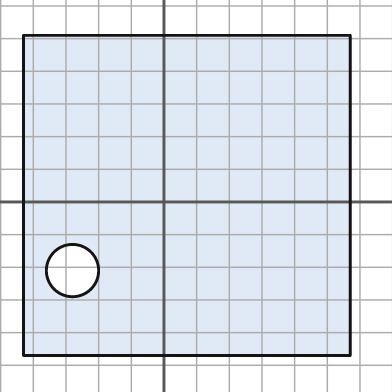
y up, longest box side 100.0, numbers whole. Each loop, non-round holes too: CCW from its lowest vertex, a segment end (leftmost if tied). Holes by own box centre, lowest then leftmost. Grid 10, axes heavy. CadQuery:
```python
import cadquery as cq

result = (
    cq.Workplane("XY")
    .moveTo(-43.0, -47.0)
    .lineTo(57.0, -47.0)
    .lineTo(57.0, 51.0)
    .lineTo(-43.0, 51.0)
    .close()
    .moveTo(-28.0, -21.0)
    .circle(8.0)
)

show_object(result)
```